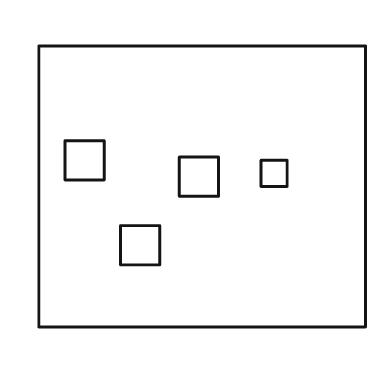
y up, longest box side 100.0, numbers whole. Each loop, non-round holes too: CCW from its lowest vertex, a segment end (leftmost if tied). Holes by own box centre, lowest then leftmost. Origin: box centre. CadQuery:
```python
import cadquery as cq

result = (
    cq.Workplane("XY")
    .moveTo(-50.0, -43.0)
    .lineTo(50.0, -43.0)
    .lineTo(50.0, 43.0)
    .lineTo(-50.0, 43.0)
    .close()
    .moveTo(-25.0, -24.0)
    .lineTo(-13.0, -24.0)
    .lineTo(-13.0, -12.0)
    .lineTo(-25.0, -12.0)
    .close()
    .moveTo(-7.0, -3.0)
    .lineTo(5.0, -3.0)
    .lineTo(5.0, 9.0)
    .lineTo(-7.0, 9.0)
    .close()
    .moveTo(18.0, 0.0)
    .lineTo(26.0, 0.0)
    .lineTo(26.0, 8.0)
    .lineTo(18.0, 8.0)
    .close()
    .moveTo(-42.0, 2.0)
    .lineTo(-30.0, 2.0)
    .lineTo(-30.0, 14.0)
    .lineTo(-42.0, 14.0)
    .close()
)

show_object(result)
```